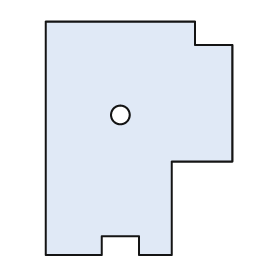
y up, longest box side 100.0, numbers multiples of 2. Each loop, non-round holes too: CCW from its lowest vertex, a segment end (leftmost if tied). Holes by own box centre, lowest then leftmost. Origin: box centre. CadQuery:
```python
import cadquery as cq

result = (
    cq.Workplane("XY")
    .moveTo(-40.0, -50.0)
    .lineTo(-16.0, -50.0)
    .lineTo(-16.0, -42.0)
    .lineTo(0.0, -42.0)
    .lineTo(0.0, -50.0)
    .lineTo(14.0, -50.0)
    .lineTo(14.0, -10.0)
    .lineTo(40.0, -10.0)
    .lineTo(40.0, 40.0)
    .lineTo(24.0, 40.0)
    .lineTo(24.0, 50.0)
    .lineTo(-40.0, 50.0)
    .close()
    .moveTo(-8.0, 10.0)
    .circle(4.0)
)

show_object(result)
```